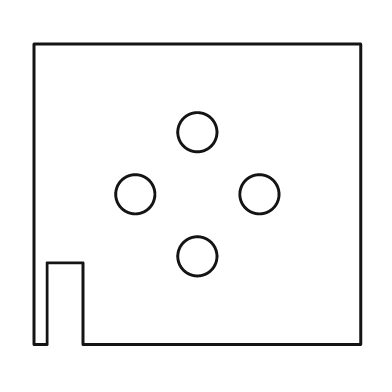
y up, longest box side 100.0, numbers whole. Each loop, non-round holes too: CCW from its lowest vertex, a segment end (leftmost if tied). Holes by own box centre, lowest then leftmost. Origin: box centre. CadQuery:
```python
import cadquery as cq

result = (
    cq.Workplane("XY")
    .moveTo(-50.0, -46.0)
    .lineTo(-46.0, -46.0)
    .lineTo(-46.0, -21.0)
    .lineTo(-35.0, -21.0)
    .lineTo(-35.0, -46.0)
    .lineTo(50.0, -46.0)
    .lineTo(50.0, 46.0)
    .lineTo(-50.0, 46.0)
    .close()
    .moveTo(0.0, -19.0)
    .circle(6.0)
    .moveTo(-19.0, 0.0)
    .circle(6.0)
    .moveTo(19.0, 0.0)
    .circle(6.0)
    .moveTo(0.0, 19.0)
    .circle(6.0)
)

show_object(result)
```